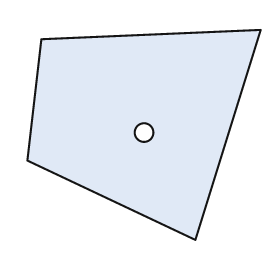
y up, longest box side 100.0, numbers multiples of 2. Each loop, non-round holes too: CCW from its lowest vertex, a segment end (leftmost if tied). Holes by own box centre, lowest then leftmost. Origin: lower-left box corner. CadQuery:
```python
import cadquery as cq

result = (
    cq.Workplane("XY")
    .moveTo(72.0, 0.0)
    .lineTo(100.0, 90.0)
    .lineTo(6.0, 86.0)
    .lineTo(0.0, 34.0)
    .close()
    .moveTo(50.0, 46.0)
    .circle(4.0)
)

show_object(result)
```